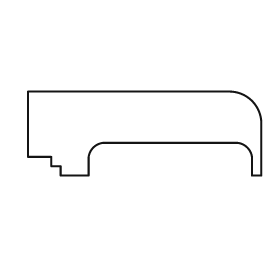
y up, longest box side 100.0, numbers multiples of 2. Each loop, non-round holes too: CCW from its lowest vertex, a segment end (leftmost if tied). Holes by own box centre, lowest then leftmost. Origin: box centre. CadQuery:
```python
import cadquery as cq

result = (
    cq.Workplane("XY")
    .moveTo(-36.0, -18.0)
    .lineTo(-24.0, -18.0)
    .lineTo(-24.0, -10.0)
    .threePointArc((-22.0, -6.0), (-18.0, -4.0))
    .lineTo(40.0, -4.0)
    .threePointArc((44.0, -6.0), (46.0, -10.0))
    .lineTo(46.0, -18.0)
    .lineTo(50.0, -18.0)
    .lineTo(50.0, 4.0)
    .threePointArc((46.0, 14.0), (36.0, 18.0))
    .lineTo(-50.0, 18.0)
    .lineTo(-50.0, -10.0)
    .lineTo(-40.0, -10.0)
    .lineTo(-40.0, -14.0)
    .lineTo(-36.0, -14.0)
    .close()
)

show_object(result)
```